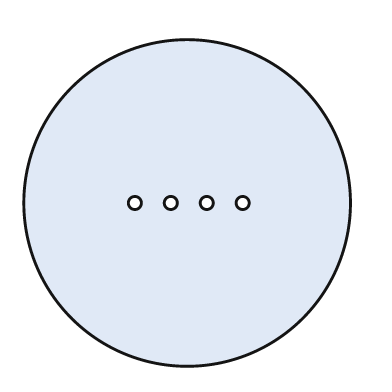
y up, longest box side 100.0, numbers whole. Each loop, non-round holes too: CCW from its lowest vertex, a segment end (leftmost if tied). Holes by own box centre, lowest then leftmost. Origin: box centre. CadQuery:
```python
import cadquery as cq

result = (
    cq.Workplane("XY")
    .moveTo(0.0, 0.0)
    .circle(50.0)
    .moveTo(-16.0, 0.0)
    .circle(2.0)
    .moveTo(-5.0, 0.0)
    .circle(2.0)
    .moveTo(6.0, 0.0)
    .circle(2.0)
    .moveTo(17.0, 0.0)
    .circle(2.0)
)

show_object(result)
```